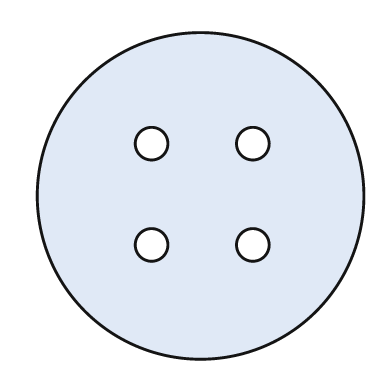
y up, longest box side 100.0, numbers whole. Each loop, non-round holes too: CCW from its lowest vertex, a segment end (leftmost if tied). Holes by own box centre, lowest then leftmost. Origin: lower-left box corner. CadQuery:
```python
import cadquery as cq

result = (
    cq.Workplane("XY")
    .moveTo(50.0, 50.0)
    .circle(50.0)
    .moveTo(35.0, 35.0)
    .circle(5.0)
    .moveTo(66.0, 35.0)
    .circle(5.0)
    .moveTo(35.0, 66.0)
    .circle(5.0)
    .moveTo(66.0, 66.0)
    .circle(5.0)
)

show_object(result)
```